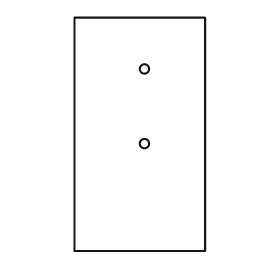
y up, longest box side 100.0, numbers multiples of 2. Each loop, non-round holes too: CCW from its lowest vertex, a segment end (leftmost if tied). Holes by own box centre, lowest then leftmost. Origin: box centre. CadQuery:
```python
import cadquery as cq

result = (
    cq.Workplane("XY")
    .moveTo(-28.0, -50.0)
    .lineTo(28.0, -50.0)
    .lineTo(28.0, 50.0)
    .lineTo(-28.0, 50.0)
    .close()
    .moveTo(2.0, -4.0)
    .circle(2.0)
    .moveTo(2.0, 28.0)
    .circle(2.0)
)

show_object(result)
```